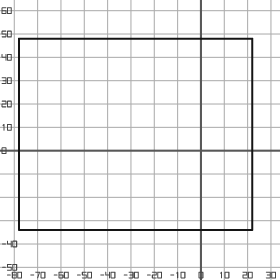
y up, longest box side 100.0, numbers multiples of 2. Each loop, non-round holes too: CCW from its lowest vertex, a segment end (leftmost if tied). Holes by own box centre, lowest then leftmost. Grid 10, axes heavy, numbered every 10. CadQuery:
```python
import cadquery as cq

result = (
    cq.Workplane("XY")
    .moveTo(-78.0, -34.0)
    .lineTo(22.0, -34.0)
    .lineTo(22.0, 48.0)
    .lineTo(-78.0, 48.0)
    .close()
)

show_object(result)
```